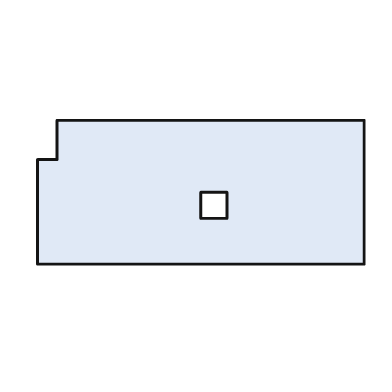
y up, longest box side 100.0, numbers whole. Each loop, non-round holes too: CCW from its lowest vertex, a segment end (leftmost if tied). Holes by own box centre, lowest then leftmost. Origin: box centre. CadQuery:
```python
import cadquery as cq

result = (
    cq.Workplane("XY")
    .moveTo(-50.0, -22.0)
    .lineTo(50.0, -22.0)
    .lineTo(50.0, 22.0)
    .lineTo(-44.0, 22.0)
    .lineTo(-44.0, 10.0)
    .lineTo(-50.0, 10.0)
    .close()
    .moveTo(0.0, -8.0)
    .lineTo(8.0, -8.0)
    .lineTo(8.0, 0.0)
    .lineTo(0.0, 0.0)
    .close()
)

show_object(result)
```